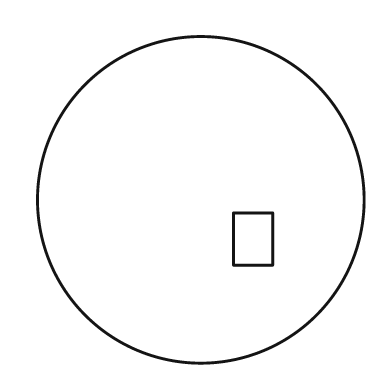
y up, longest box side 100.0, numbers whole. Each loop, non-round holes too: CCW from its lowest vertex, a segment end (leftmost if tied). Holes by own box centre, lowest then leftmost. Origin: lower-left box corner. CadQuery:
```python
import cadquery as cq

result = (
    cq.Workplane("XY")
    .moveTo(50.0, 50.0)
    .circle(50.0)
    .moveTo(60.0, 30.0)
    .lineTo(72.0, 30.0)
    .lineTo(72.0, 46.0)
    .lineTo(60.0, 46.0)
    .close()
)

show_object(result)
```